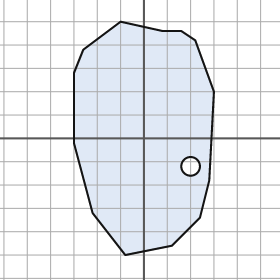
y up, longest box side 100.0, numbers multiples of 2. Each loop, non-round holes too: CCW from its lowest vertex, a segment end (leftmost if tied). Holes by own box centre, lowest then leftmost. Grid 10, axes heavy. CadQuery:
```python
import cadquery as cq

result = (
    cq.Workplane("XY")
    .moveTo(-8.0, -50.0)
    .lineTo(12.0, -46.0)
    .lineTo(24.0, -34.0)
    .lineTo(28.0, -18.0)
    .lineTo(30.0, 20.0)
    .lineTo(22.0, 42.0)
    .lineTo(16.0, 46.0)
    .lineTo(8.0, 46.0)
    .lineTo(-10.0, 50.0)
    .lineTo(-26.0, 38.0)
    .lineTo(-30.0, 28.0)
    .lineTo(-30.0, -2.0)
    .lineTo(-22.0, -32.0)
    .close()
    .moveTo(20.0, -12.0)
    .circle(4.0)
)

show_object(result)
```